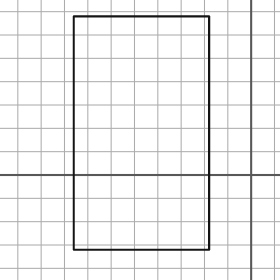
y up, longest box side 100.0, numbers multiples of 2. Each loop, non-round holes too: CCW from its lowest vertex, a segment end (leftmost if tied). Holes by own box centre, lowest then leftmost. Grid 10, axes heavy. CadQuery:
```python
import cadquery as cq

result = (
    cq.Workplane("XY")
    .moveTo(-76.0, -32.0)
    .lineTo(-18.0, -32.0)
    .lineTo(-18.0, 68.0)
    .lineTo(-76.0, 68.0)
    .close()
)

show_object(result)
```